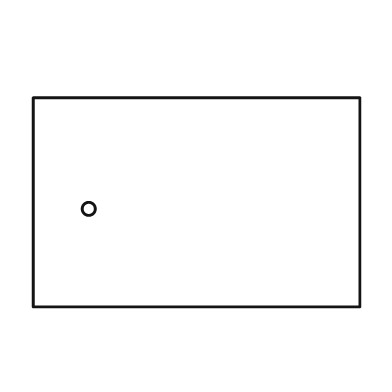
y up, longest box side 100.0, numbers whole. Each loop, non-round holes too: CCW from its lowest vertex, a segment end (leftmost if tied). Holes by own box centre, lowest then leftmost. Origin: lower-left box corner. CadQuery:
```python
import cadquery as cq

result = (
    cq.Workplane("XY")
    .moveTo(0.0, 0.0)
    .lineTo(100.0, 0.0)
    .lineTo(100.0, 64.0)
    .lineTo(0.0, 64.0)
    .close()
    .moveTo(17.0, 30.0)
    .circle(2.0)
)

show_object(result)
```